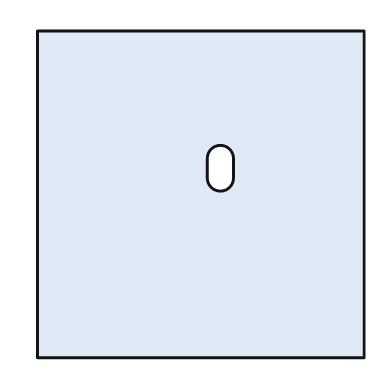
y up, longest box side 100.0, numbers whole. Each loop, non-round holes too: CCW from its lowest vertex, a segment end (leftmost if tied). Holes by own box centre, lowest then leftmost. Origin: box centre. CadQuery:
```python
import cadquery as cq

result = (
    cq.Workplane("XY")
    .moveTo(-50.0, -50.0)
    .lineTo(50.0, -50.0)
    .lineTo(50.0, 50.0)
    .lineTo(-50.0, 50.0)
    .close()
    .moveTo(2.0, 5.0)
    .threePointArc((6.0, 1.0), (10.0, 5.0))
    .lineTo(10.0, 11.0)
    .threePointArc((6.0, 15.0), (2.0, 11.0))
    .close()
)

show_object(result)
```